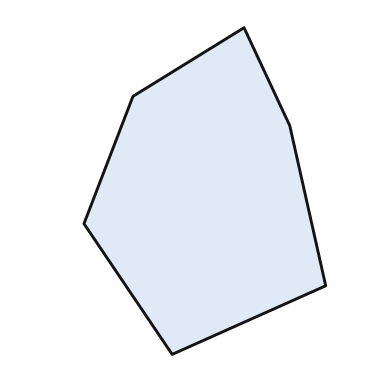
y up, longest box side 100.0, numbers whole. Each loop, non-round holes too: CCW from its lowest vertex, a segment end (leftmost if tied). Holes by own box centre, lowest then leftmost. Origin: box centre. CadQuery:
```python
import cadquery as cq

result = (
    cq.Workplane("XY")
    .moveTo(-10.0, -50.0)
    .lineTo(37.0, -29.0)
    .lineTo(26.0, 20.0)
    .lineTo(12.0, 50.0)
    .lineTo(-22.0, 29.0)
    .lineTo(-37.0, -10.0)
    .close()
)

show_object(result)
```